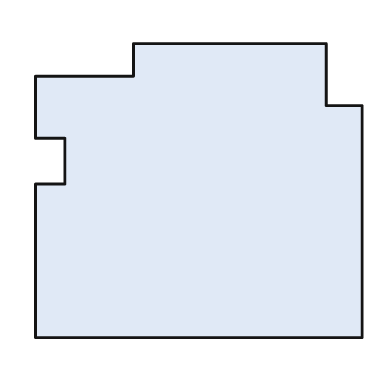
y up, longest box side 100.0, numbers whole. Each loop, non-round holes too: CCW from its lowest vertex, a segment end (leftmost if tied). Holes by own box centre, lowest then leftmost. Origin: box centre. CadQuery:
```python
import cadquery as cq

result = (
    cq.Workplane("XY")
    .moveTo(-50.0, -45.0)
    .lineTo(50.0, -45.0)
    .lineTo(50.0, 26.0)
    .lineTo(39.0, 26.0)
    .lineTo(39.0, 45.0)
    .lineTo(-20.0, 45.0)
    .lineTo(-20.0, 35.0)
    .lineTo(-50.0, 35.0)
    .lineTo(-50.0, 16.0)
    .lineTo(-41.0, 16.0)
    .lineTo(-41.0, 2.0)
    .lineTo(-50.0, 2.0)
    .close()
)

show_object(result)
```